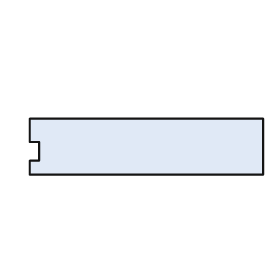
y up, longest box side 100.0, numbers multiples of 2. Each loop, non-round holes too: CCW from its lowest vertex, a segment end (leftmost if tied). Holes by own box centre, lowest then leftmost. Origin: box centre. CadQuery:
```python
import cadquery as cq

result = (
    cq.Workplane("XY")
    .moveTo(-50.0, -12.0)
    .lineTo(50.0, -12.0)
    .lineTo(50.0, 12.0)
    .lineTo(-50.0, 12.0)
    .lineTo(-50.0, 2.0)
    .lineTo(-46.0, 2.0)
    .lineTo(-46.0, -6.0)
    .lineTo(-50.0, -6.0)
    .close()
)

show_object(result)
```